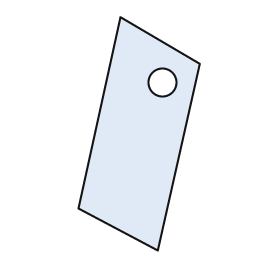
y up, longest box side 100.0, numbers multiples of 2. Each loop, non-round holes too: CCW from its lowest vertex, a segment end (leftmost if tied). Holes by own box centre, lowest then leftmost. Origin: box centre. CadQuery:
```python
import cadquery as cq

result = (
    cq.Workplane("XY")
    .moveTo(8.0, -50.0)
    .lineTo(26.0, 30.0)
    .lineTo(-8.0, 50.0)
    .lineTo(-26.0, -32.0)
    .close()
    .moveTo(10.0, 22.0)
    .circle(6.0)
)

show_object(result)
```